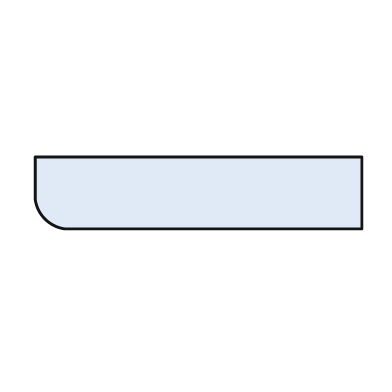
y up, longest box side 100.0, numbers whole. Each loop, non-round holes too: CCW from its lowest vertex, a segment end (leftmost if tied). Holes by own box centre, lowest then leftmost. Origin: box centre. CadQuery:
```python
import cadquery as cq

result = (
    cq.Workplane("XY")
    .moveTo(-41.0, -11.0)
    .lineTo(50.0, -11.0)
    .lineTo(50.0, 11.0)
    .lineTo(-50.0, 11.0)
    .lineTo(-50.0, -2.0)
    .threePointArc((-47.0, -8.0), (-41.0, -11.0))
    .close()
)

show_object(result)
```